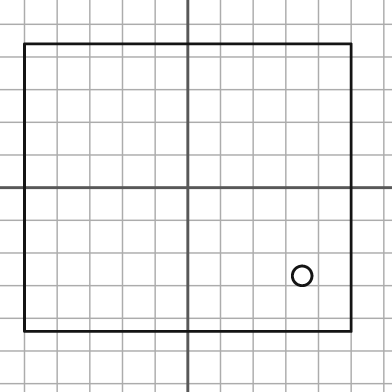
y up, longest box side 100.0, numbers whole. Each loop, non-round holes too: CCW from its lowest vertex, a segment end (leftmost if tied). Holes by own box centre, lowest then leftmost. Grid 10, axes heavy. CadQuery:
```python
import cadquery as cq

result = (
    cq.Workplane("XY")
    .moveTo(-50.0, -44.0)
    .lineTo(50.0, -44.0)
    .lineTo(50.0, 44.0)
    .lineTo(-50.0, 44.0)
    .close()
    .moveTo(35.0, -27.0)
    .circle(3.0)
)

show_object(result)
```